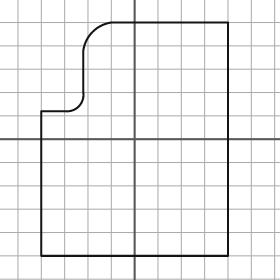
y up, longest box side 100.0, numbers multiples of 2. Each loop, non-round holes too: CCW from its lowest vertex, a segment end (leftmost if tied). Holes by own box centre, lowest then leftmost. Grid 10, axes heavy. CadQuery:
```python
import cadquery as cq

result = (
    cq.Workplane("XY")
    .moveTo(-40.0, -50.0)
    .lineTo(40.0, -50.0)
    .lineTo(40.0, 50.0)
    .lineTo(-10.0, 50.0)
    .threePointArc((-18.0, 46.0), (-22.0, 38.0))
    .lineTo(-22.0, 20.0)
    .threePointArc((-24.0, 14.0), (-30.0, 12.0))
    .lineTo(-40.0, 12.0)
    .close()
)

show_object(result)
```